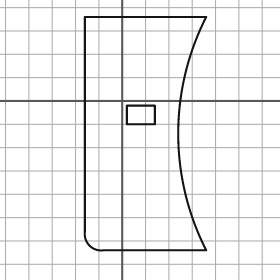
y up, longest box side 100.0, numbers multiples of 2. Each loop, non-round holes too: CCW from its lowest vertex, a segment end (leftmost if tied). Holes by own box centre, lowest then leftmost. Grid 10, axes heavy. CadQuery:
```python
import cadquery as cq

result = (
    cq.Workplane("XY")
    .moveTo(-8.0, -64.0)
    .lineTo(36.0, -64.0)
    .threePointArc((24.0, -14.0), (36.0, 36.0))
    .lineTo(-16.0, 36.0)
    .lineTo(-16.0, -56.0)
    .threePointArc((-14.0, -62.0), (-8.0, -64.0))
    .close()
    .moveTo(2.0, -10.0)
    .lineTo(14.0, -10.0)
    .lineTo(14.0, -2.0)
    .lineTo(2.0, -2.0)
    .close()
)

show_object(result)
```